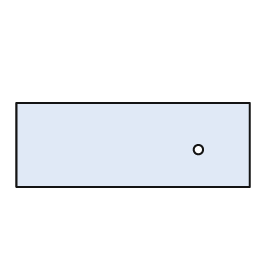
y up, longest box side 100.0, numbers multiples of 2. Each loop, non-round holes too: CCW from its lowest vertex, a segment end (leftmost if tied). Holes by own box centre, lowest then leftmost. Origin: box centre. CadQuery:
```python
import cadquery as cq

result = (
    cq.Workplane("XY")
    .moveTo(-50.0, -18.0)
    .lineTo(50.0, -18.0)
    .lineTo(50.0, 18.0)
    .lineTo(-50.0, 18.0)
    .close()
    .moveTo(28.0, -2.0)
    .circle(2.0)
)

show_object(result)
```